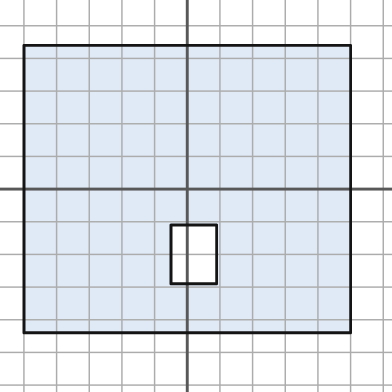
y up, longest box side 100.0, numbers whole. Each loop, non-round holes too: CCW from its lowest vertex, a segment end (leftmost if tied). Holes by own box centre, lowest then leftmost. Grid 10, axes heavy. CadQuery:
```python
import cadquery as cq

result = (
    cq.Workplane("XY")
    .moveTo(-50.0, -44.0)
    .lineTo(50.0, -44.0)
    .lineTo(50.0, 44.0)
    .lineTo(-50.0, 44.0)
    .close()
    .moveTo(-5.0, -29.0)
    .lineTo(9.0, -29.0)
    .lineTo(9.0, -11.0)
    .lineTo(-5.0, -11.0)
    .close()
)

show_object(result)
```